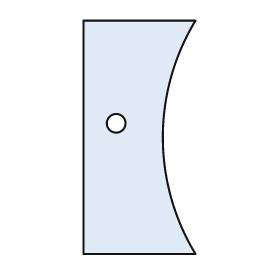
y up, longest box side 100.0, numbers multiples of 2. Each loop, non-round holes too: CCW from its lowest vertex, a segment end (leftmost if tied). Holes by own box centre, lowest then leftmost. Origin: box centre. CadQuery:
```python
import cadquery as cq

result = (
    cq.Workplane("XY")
    .moveTo(-24.0, -50.0)
    .lineTo(24.0, -50.0)
    .threePointArc((10.0, 0.0), (24.0, 50.0))
    .lineTo(-24.0, 50.0)
    .close()
    .moveTo(-10.0, 6.0)
    .circle(4.0)
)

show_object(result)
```